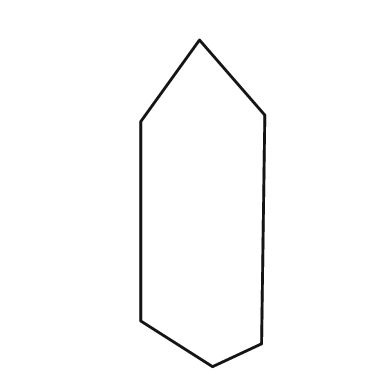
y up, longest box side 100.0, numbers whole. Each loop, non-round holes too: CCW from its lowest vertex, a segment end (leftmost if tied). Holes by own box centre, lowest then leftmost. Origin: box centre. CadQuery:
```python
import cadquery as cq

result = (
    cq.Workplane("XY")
    .moveTo(3.0, -50.0)
    .lineTo(18.0, -43.0)
    .lineTo(19.0, 27.0)
    .lineTo(-1.0, 50.0)
    .lineTo(-19.0, 25.0)
    .lineTo(-19.0, -36.0)
    .close()
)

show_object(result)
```